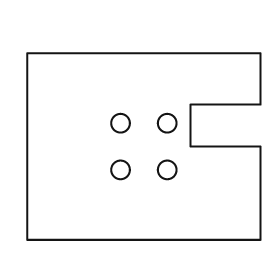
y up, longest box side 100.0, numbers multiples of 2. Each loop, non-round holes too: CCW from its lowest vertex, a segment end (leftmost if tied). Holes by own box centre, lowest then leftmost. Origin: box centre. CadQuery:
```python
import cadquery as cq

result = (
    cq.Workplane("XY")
    .moveTo(-50.0, -40.0)
    .lineTo(50.0, -40.0)
    .lineTo(50.0, 0.0)
    .lineTo(20.0, 0.0)
    .lineTo(20.0, 18.0)
    .lineTo(50.0, 18.0)
    .lineTo(50.0, 40.0)
    .lineTo(-50.0, 40.0)
    .close()
    .moveTo(-10.0, -10.0)
    .circle(4.0)
    .moveTo(10.0, -10.0)
    .circle(4.0)
    .moveTo(-10.0, 10.0)
    .circle(4.0)
    .moveTo(10.0, 10.0)
    .circle(4.0)
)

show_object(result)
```